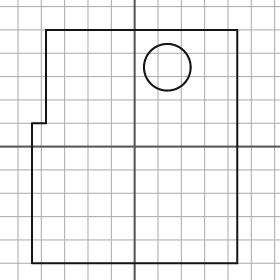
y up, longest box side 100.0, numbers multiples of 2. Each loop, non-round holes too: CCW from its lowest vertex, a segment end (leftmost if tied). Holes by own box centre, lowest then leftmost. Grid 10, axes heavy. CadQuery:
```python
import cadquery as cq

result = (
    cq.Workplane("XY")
    .moveTo(-44.0, -50.0)
    .lineTo(44.0, -50.0)
    .lineTo(44.0, 50.0)
    .lineTo(-38.0, 50.0)
    .lineTo(-38.0, 10.0)
    .lineTo(-44.0, 10.0)
    .close()
    .moveTo(14.0, 34.0)
    .circle(10.0)
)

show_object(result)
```